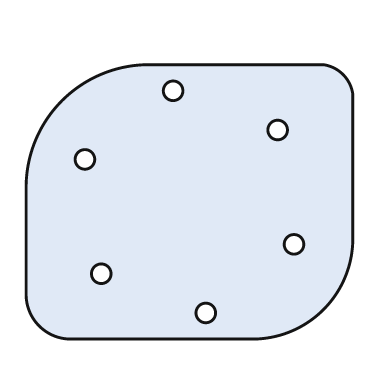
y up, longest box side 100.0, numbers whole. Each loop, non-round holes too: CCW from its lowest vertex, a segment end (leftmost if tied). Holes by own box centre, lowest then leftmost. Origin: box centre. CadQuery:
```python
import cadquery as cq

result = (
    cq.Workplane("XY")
    .moveTo(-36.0, -42.0)
    .lineTo(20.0, -42.0)
    .threePointArc((41.0, -33.0), (50.0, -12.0))
    .lineTo(50.0, 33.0)
    .threePointArc((47.0, 39.0), (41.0, 42.0))
    .lineTo(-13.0, 42.0)
    .threePointArc((-39.0, 31.0), (-50.0, 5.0))
    .lineTo(-50.0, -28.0)
    .threePointArc((-46.0, -38.0), (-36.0, -42.0))
    .close()
    .moveTo(5.0, -34.0)
    .circle(3.0)
    .moveTo(-27.0, -22.0)
    .circle(3.0)
    .moveTo(32.0, -13.0)
    .circle(3.0)
    .moveTo(-32.0, 13.0)
    .circle(3.0)
    .moveTo(27.0, 22.0)
    .circle(3.0)
    .moveTo(-5.0, 34.0)
    .circle(3.0)
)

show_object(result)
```